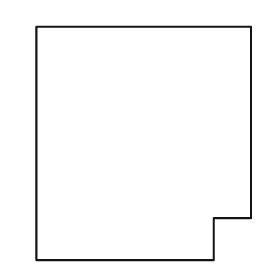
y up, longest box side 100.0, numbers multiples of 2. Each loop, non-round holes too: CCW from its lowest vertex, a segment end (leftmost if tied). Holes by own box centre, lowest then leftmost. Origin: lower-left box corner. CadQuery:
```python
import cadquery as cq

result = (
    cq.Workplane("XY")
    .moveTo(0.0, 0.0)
    .lineTo(76.0, 0.0)
    .lineTo(76.0, 18.0)
    .lineTo(92.0, 18.0)
    .lineTo(92.0, 100.0)
    .lineTo(0.0, 100.0)
    .close()
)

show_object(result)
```